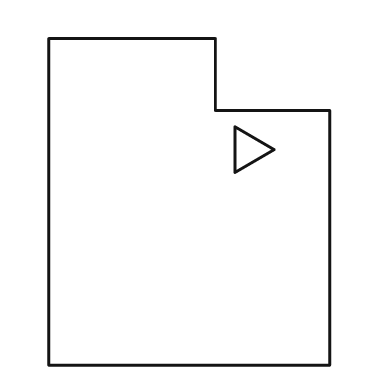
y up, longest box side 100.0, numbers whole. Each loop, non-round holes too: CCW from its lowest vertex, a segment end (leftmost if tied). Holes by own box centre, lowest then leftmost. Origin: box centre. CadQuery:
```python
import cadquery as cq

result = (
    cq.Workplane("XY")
    .moveTo(-43.0, -50.0)
    .lineTo(43.0, -50.0)
    .lineTo(43.0, 28.0)
    .lineTo(8.0, 28.0)
    .lineTo(8.0, 50.0)
    .lineTo(-43.0, 50.0)
    .close()
    .moveTo(14.0, 9.0)
    .lineTo(26.0, 16.0)
    .lineTo(14.0, 23.0)
    .close()
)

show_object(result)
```